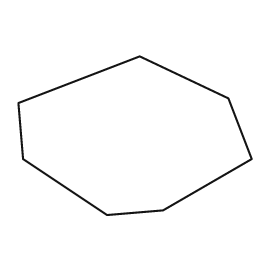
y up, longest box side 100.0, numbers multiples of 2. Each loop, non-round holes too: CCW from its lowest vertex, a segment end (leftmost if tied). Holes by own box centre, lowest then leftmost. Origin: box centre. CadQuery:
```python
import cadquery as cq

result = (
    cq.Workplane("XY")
    .moveTo(-12.0, -34.0)
    .lineTo(12.0, -32.0)
    .lineTo(50.0, -10.0)
    .lineTo(40.0, 16.0)
    .lineTo(2.0, 34.0)
    .lineTo(-50.0, 14.0)
    .lineTo(-48.0, -10.0)
    .close()
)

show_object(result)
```